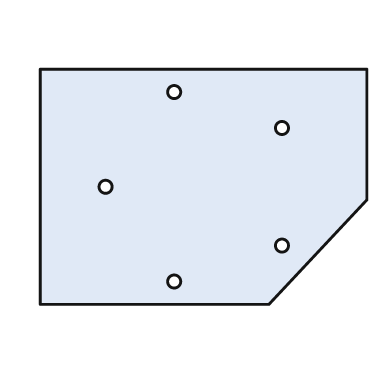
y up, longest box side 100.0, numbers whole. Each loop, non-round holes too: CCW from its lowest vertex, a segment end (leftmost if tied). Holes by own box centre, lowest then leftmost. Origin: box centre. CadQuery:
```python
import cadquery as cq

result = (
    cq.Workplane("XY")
    .moveTo(-50.0, -36.0)
    .lineTo(20.0, -36.0)
    .lineTo(50.0, -4.0)
    .lineTo(50.0, 36.0)
    .lineTo(-50.0, 36.0)
    .close()
    .moveTo(-9.0, -29.0)
    .circle(2.0)
    .moveTo(24.0, -18.0)
    .circle(2.0)
    .moveTo(-30.0, 0.0)
    .circle(2.0)
    .moveTo(24.0, 18.0)
    .circle(2.0)
    .moveTo(-9.0, 29.0)
    .circle(2.0)
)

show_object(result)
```